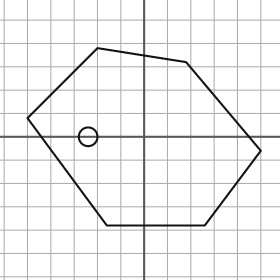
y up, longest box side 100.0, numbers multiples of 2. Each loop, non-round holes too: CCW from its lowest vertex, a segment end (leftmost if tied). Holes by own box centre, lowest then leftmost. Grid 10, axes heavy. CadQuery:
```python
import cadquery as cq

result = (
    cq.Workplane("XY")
    .moveTo(-16.0, -38.0)
    .lineTo(26.0, -38.0)
    .lineTo(50.0, -6.0)
    .lineTo(18.0, 32.0)
    .lineTo(-20.0, 38.0)
    .lineTo(-50.0, 8.0)
    .close()
    .moveTo(-24.0, 0.0)
    .circle(4.0)
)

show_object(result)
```